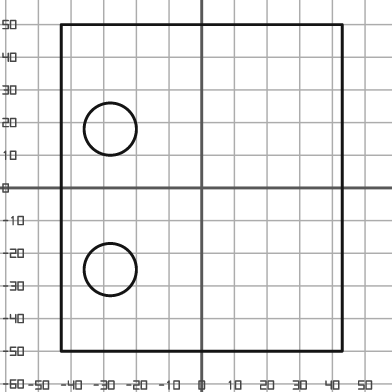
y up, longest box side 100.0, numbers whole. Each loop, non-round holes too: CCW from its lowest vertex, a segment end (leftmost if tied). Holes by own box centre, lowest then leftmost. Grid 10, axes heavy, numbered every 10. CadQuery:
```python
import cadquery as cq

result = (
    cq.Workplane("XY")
    .moveTo(-43.0, -50.0)
    .lineTo(43.0, -50.0)
    .lineTo(43.0, 50.0)
    .lineTo(-43.0, 50.0)
    .close()
    .moveTo(-28.0, -25.0)
    .circle(8.0)
    .moveTo(-28.0, 18.0)
    .circle(8.0)
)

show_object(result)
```